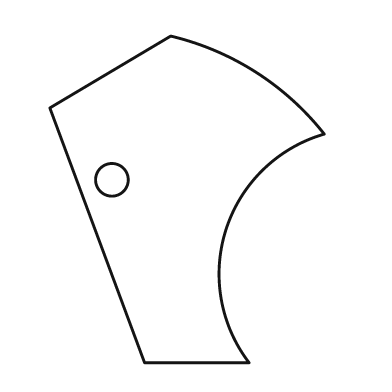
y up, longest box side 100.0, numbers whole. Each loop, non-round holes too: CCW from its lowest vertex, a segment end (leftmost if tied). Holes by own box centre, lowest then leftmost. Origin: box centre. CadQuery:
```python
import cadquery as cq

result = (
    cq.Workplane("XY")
    .moveTo(-13.0, -50.0)
    .lineTo(19.0, -50.0)
    .threePointArc((12.0, -9.0), (42.0, 20.0))
    .threePointArc((21.0, 39.0), (-5.0, 50.0))
    .lineTo(-42.0, 28.0)
    .close()
    .moveTo(-23.0, 6.0)
    .circle(5.0)
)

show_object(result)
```